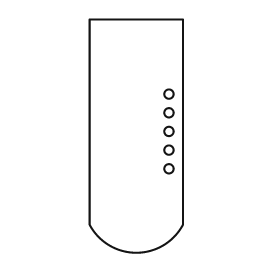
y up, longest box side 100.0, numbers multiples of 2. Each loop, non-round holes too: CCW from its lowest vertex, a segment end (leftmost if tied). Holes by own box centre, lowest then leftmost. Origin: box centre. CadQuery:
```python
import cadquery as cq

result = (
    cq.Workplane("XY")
    .moveTo(-20.0, -38.0)
    .threePointArc((0.0, -50.0), (20.0, -38.0))
    .lineTo(20.0, 50.0)
    .lineTo(-20.0, 50.0)
    .close()
    .moveTo(14.0, -14.0)
    .circle(2.0)
    .moveTo(14.0, -6.0)
    .circle(2.0)
    .moveTo(14.0, 2.0)
    .circle(2.0)
    .moveTo(14.0, 10.0)
    .circle(2.0)
    .moveTo(14.0, 18.0)
    .circle(2.0)
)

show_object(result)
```